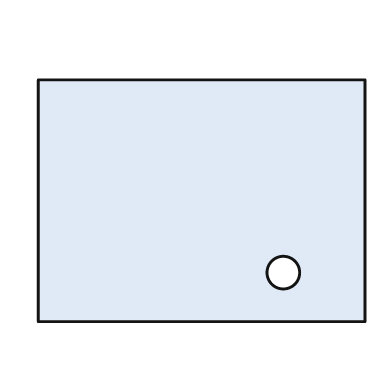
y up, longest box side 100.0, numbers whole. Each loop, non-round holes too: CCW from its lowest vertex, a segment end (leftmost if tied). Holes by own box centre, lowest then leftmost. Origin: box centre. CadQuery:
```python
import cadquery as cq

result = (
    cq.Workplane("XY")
    .moveTo(-50.0, -37.0)
    .lineTo(50.0, -37.0)
    .lineTo(50.0, 37.0)
    .lineTo(-50.0, 37.0)
    .close()
    .moveTo(25.0, -22.0)
    .circle(5.0)
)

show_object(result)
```